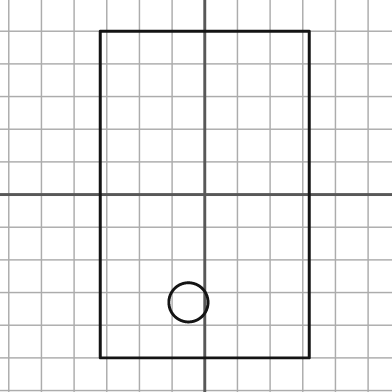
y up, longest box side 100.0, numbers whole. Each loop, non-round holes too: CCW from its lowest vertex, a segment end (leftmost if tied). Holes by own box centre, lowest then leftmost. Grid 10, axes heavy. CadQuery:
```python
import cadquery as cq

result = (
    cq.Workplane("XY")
    .moveTo(-32.0, -50.0)
    .lineTo(32.0, -50.0)
    .lineTo(32.0, 50.0)
    .lineTo(-32.0, 50.0)
    .close()
    .moveTo(-5.0, -33.0)
    .circle(6.0)
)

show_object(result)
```